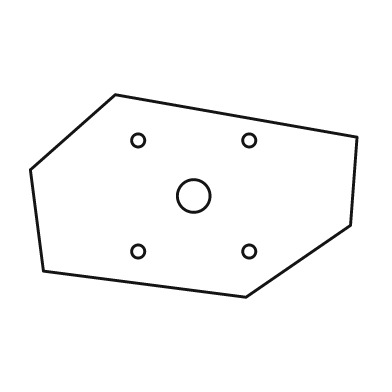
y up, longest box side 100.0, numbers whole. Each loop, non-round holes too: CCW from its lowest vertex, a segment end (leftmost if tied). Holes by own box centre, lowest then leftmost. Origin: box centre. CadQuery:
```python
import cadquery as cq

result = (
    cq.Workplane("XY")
    .moveTo(16.0, -31.0)
    .lineTo(48.0, -9.0)
    .lineTo(50.0, 18.0)
    .lineTo(-24.0, 31.0)
    .lineTo(-50.0, 8.0)
    .lineTo(-46.0, -23.0)
    .close()
    .moveTo(-17.0, -17.0)
    .circle(2.0)
    .moveTo(17.0, -17.0)
    .circle(2.0)
    .moveTo(0.0, 0.0)
    .circle(5.0)
    .moveTo(-17.0, 17.0)
    .circle(2.0)
    .moveTo(17.0, 17.0)
    .circle(2.0)
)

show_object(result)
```